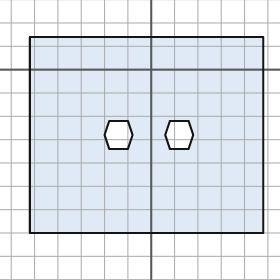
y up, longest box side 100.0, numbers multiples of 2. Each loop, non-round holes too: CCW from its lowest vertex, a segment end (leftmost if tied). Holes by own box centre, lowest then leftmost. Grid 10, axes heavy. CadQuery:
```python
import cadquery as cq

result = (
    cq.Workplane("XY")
    .moveTo(-52.0, -70.0)
    .lineTo(48.0, -70.0)
    .lineTo(48.0, 14.0)
    .lineTo(-52.0, 14.0)
    .close()
    .moveTo(-18.0, -34.0)
    .lineTo(-10.0, -34.0)
    .lineTo(-8.0, -28.0)
    .lineTo(-10.0, -22.0)
    .lineTo(-18.0, -22.0)
    .lineTo(-20.0, -28.0)
    .close()
    .moveTo(8.0, -34.0)
    .lineTo(16.0, -34.0)
    .lineTo(18.0, -28.0)
    .lineTo(16.0, -22.0)
    .lineTo(8.0, -22.0)
    .lineTo(6.0, -28.0)
    .close()
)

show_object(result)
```